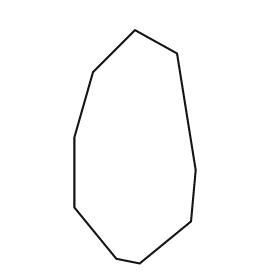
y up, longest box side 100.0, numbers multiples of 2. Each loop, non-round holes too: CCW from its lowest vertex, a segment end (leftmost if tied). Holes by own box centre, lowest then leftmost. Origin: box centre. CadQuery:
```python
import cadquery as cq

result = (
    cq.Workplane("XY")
    .moveTo(2.0, -50.0)
    .lineTo(24.0, -32.0)
    .lineTo(26.0, -10.0)
    .lineTo(18.0, 40.0)
    .lineTo(0.0, 50.0)
    .lineTo(-18.0, 32.0)
    .lineTo(-26.0, 4.0)
    .lineTo(-26.0, -26.0)
    .lineTo(-8.0, -48.0)
    .close()
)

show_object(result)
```